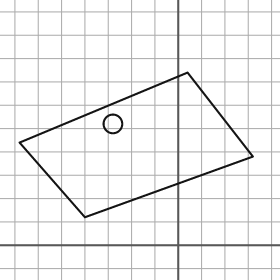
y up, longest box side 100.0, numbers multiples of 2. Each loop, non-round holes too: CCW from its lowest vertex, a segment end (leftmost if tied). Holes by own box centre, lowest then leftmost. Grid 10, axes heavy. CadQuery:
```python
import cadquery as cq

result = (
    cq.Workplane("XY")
    .moveTo(-40.0, 12.0)
    .lineTo(32.0, 38.0)
    .lineTo(4.0, 74.0)
    .lineTo(-68.0, 44.0)
    .close()
    .moveTo(-28.0, 52.0)
    .circle(4.0)
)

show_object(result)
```